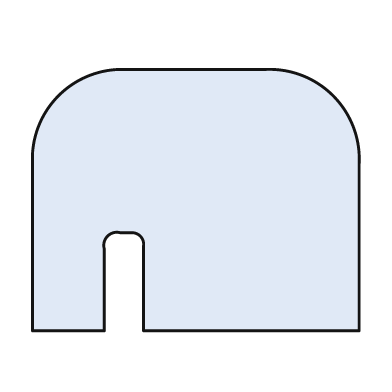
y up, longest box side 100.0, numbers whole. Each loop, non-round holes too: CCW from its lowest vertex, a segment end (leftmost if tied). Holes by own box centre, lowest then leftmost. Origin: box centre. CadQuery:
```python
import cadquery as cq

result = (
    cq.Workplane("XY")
    .moveTo(-50.0, -40.0)
    .lineTo(-28.0, -40.0)
    .lineTo(-28.0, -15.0)
    .threePointArc((-27.0, -11.0), (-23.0, -10.0))
    .lineTo(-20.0, -10.0)
    .threePointArc((-17.0, -11.0), (-16.0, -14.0))
    .lineTo(-16.0, -40.0)
    .lineTo(50.0, -40.0)
    .lineTo(50.0, 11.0)
    .threePointArc((42.0, 32.0), (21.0, 40.0))
    .lineTo(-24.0, 40.0)
    .threePointArc((-42.0, 32.0), (-50.0, 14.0))
    .close()
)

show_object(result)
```